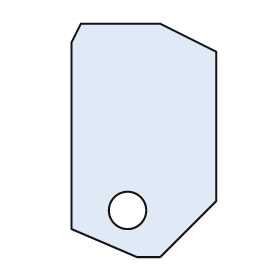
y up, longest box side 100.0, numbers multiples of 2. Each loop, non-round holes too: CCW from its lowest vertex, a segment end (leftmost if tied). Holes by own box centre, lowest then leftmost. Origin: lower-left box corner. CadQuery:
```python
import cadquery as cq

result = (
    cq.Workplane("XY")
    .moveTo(28.0, 0.0)
    .lineTo(38.0, 0.0)
    .lineTo(62.0, 24.0)
    .lineTo(62.0, 88.0)
    .lineTo(38.0, 100.0)
    .lineTo(4.0, 100.0)
    .lineTo(0.0, 92.0)
    .lineTo(0.0, 12.0)
    .close()
    .moveTo(24.0, 20.0)
    .circle(8.0)
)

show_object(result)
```